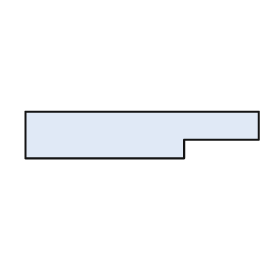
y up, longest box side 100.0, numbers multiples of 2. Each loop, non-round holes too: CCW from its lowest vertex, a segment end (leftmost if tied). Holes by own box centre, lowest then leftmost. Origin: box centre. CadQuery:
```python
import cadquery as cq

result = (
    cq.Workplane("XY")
    .moveTo(-50.0, -10.0)
    .lineTo(18.0, -10.0)
    .lineTo(18.0, -2.0)
    .lineTo(50.0, -2.0)
    .lineTo(50.0, 10.0)
    .lineTo(-50.0, 10.0)
    .close()
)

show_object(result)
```